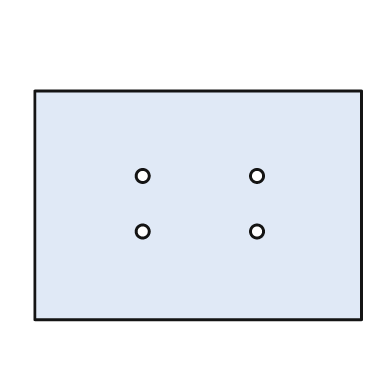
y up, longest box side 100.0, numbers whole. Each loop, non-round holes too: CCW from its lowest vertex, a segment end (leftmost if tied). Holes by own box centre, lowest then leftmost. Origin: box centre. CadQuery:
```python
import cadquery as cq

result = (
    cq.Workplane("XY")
    .moveTo(-50.0, -35.0)
    .lineTo(50.0, -35.0)
    .lineTo(50.0, 35.0)
    .lineTo(-50.0, 35.0)
    .close()
    .moveTo(-17.0, -8.0)
    .circle(2.0)
    .moveTo(18.0, -8.0)
    .circle(2.0)
    .moveTo(-17.0, 9.0)
    .circle(2.0)
    .moveTo(18.0, 9.0)
    .circle(2.0)
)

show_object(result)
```